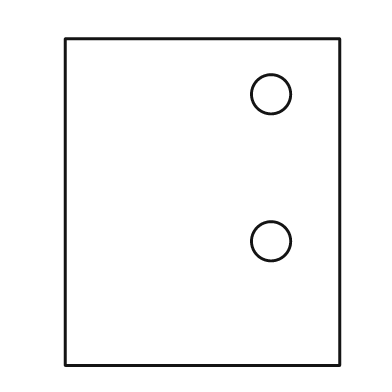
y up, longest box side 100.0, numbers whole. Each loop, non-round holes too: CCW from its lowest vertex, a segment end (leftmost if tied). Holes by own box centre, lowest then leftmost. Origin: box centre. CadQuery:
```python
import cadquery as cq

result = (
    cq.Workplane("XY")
    .moveTo(-42.0, -50.0)
    .lineTo(42.0, -50.0)
    .lineTo(42.0, 50.0)
    .lineTo(-42.0, 50.0)
    .close()
    .moveTo(21.0, -12.0)
    .circle(6.0)
    .moveTo(21.0, 33.0)
    .circle(6.0)
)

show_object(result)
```